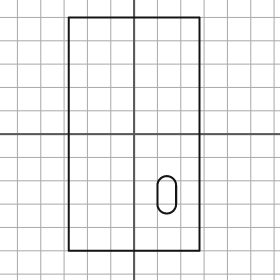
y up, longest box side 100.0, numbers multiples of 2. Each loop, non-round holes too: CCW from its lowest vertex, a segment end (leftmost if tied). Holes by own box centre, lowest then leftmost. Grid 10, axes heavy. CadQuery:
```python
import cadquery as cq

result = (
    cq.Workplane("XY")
    .moveTo(-28.0, -50.0)
    .lineTo(28.0, -50.0)
    .lineTo(28.0, 50.0)
    .lineTo(-28.0, 50.0)
    .close()
    .moveTo(10.0, -30.0)
    .threePointArc((14.0, -34.0), (18.0, -30.0))
    .lineTo(18.0, -22.0)
    .threePointArc((14.0, -18.0), (10.0, -22.0))
    .close()
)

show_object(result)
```